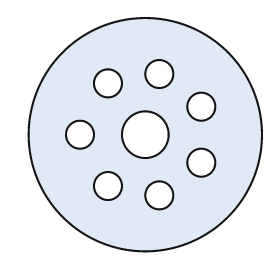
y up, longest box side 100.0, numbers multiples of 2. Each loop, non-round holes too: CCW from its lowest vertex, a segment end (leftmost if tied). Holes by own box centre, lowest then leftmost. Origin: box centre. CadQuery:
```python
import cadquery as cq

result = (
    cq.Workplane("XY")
    .moveTo(0.0, 0.0)
    .circle(50.0)
    .moveTo(6.0, -26.0)
    .circle(6.0)
    .moveTo(-16.0, -22.0)
    .circle(6.0)
    .moveTo(24.0, -12.0)
    .circle(6.0)
    .moveTo(-28.0, 0.0)
    .circle(6.0)
    .moveTo(0.0, 0.0)
    .circle(10.0)
    .moveTo(24.0, 12.0)
    .circle(6.0)
    .moveTo(-16.0, 22.0)
    .circle(6.0)
    .moveTo(6.0, 26.0)
    .circle(6.0)
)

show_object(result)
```